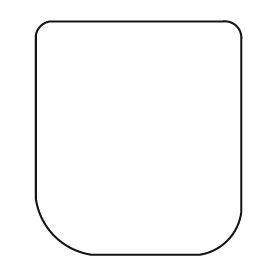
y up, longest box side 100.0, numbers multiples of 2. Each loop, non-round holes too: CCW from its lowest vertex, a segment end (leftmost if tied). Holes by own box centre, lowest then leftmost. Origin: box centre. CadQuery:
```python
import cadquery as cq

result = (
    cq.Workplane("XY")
    .moveTo(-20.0, -50.0)
    .lineTo(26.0, -50.0)
    .threePointArc((38.0, -44.0), (44.0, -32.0))
    .lineTo(44.0, 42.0)
    .threePointArc((42.0, 48.0), (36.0, 50.0))
    .lineTo(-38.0, 50.0)
    .threePointArc((-42.0, 48.0), (-44.0, 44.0))
    .lineTo(-44.0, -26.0)
    .threePointArc((-36.0, -42.0), (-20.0, -50.0))
    .close()
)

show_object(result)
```